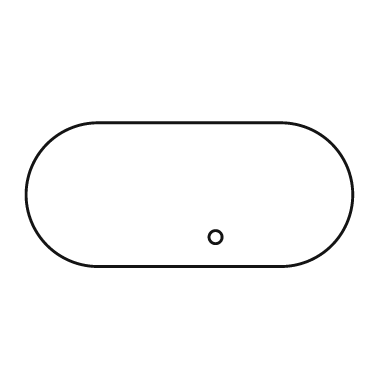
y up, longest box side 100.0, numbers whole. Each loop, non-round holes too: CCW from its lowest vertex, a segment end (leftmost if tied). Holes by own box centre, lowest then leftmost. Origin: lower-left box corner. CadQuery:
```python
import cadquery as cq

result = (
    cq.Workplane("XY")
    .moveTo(22.0, 0.0)
    .lineTo(78.0, 0.0)
    .threePointArc((100.0, 22.0), (78.0, 44.0))
    .lineTo(22.0, 44.0)
    .threePointArc((0.0, 22.0), (22.0, 0.0))
    .close()
    .moveTo(58.0, 9.0)
    .circle(2.0)
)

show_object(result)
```